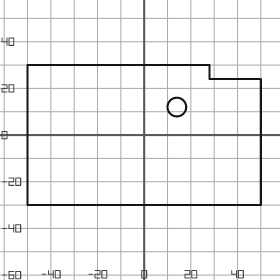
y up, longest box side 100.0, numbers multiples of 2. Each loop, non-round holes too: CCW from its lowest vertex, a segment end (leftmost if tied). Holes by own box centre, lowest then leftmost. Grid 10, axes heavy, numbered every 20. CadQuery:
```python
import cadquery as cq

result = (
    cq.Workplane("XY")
    .moveTo(-50.0, -30.0)
    .lineTo(50.0, -30.0)
    .lineTo(50.0, 24.0)
    .lineTo(28.0, 24.0)
    .lineTo(28.0, 30.0)
    .lineTo(-50.0, 30.0)
    .close()
    .moveTo(14.0, 12.0)
    .circle(4.0)
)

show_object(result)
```